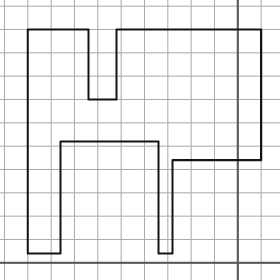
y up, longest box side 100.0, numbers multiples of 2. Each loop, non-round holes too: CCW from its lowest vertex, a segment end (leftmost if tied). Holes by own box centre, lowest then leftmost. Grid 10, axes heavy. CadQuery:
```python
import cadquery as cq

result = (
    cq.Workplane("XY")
    .moveTo(-90.0, 4.0)
    .lineTo(-76.0, 4.0)
    .lineTo(-76.0, 52.0)
    .lineTo(-34.0, 52.0)
    .lineTo(-34.0, 4.0)
    .lineTo(-28.0, 4.0)
    .lineTo(-28.0, 44.0)
    .lineTo(10.0, 44.0)
    .lineTo(10.0, 100.0)
    .lineTo(-52.0, 100.0)
    .lineTo(-52.0, 70.0)
    .lineTo(-64.0, 70.0)
    .lineTo(-64.0, 100.0)
    .lineTo(-90.0, 100.0)
    .close()
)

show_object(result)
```